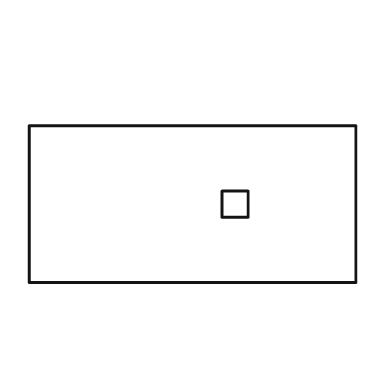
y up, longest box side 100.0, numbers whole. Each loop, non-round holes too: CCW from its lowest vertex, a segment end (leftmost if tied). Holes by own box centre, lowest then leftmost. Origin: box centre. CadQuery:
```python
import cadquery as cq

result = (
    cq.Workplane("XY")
    .moveTo(-50.0, -24.0)
    .lineTo(50.0, -24.0)
    .lineTo(50.0, 24.0)
    .lineTo(-50.0, 24.0)
    .close()
    .moveTo(9.0, -4.0)
    .lineTo(17.0, -4.0)
    .lineTo(17.0, 4.0)
    .lineTo(9.0, 4.0)
    .close()
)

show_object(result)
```